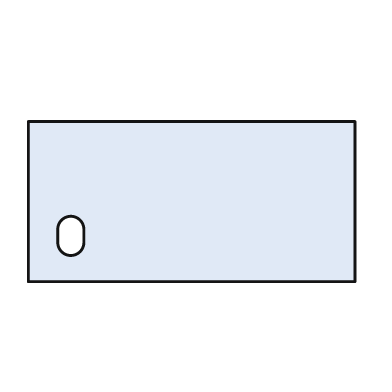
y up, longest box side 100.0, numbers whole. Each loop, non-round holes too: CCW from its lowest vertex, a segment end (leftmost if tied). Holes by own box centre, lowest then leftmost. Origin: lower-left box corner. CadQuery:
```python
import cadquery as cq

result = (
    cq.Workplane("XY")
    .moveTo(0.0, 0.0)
    .lineTo(100.0, 0.0)
    .lineTo(100.0, 49.0)
    .lineTo(0.0, 49.0)
    .close()
    .moveTo(9.0, 12.0)
    .threePointArc((13.0, 8.0), (17.0, 12.0))
    .lineTo(17.0, 16.0)
    .threePointArc((13.0, 20.0), (9.0, 16.0))
    .close()
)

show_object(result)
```